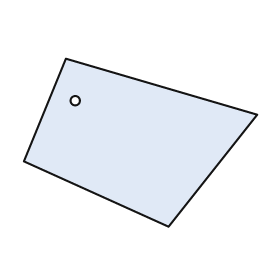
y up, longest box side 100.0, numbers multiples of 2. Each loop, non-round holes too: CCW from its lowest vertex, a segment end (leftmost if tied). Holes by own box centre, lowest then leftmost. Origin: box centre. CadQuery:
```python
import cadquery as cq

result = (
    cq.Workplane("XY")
    .moveTo(12.0, -36.0)
    .lineTo(50.0, 12.0)
    .lineTo(-32.0, 36.0)
    .lineTo(-50.0, -8.0)
    .close()
    .moveTo(-28.0, 18.0)
    .circle(2.0)
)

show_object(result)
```